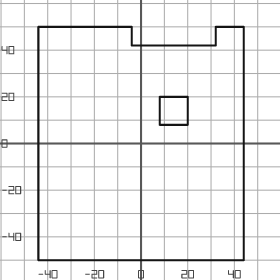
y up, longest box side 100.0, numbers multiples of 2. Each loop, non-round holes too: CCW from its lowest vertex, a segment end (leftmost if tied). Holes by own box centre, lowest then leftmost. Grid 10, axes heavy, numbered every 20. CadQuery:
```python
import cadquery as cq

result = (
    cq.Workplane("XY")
    .moveTo(-44.0, -50.0)
    .lineTo(44.0, -50.0)
    .lineTo(44.0, 50.0)
    .lineTo(32.0, 50.0)
    .lineTo(32.0, 42.0)
    .lineTo(-4.0, 42.0)
    .lineTo(-4.0, 50.0)
    .lineTo(-44.0, 50.0)
    .close()
    .moveTo(8.0, 8.0)
    .lineTo(20.0, 8.0)
    .lineTo(20.0, 20.0)
    .lineTo(8.0, 20.0)
    .close()
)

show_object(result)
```